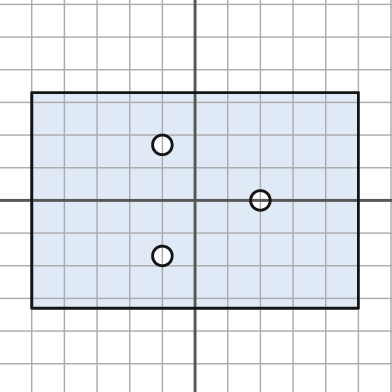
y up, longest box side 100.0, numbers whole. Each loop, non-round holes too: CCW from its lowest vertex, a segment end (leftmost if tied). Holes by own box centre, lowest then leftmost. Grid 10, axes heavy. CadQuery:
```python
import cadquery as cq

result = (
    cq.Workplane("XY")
    .moveTo(-50.0, -33.0)
    .lineTo(50.0, -33.0)
    .lineTo(50.0, 33.0)
    .lineTo(-50.0, 33.0)
    .close()
    .moveTo(-10.0, -17.0)
    .circle(3.0)
    .moveTo(20.0, 0.0)
    .circle(3.0)
    .moveTo(-10.0, 17.0)
    .circle(3.0)
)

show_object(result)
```